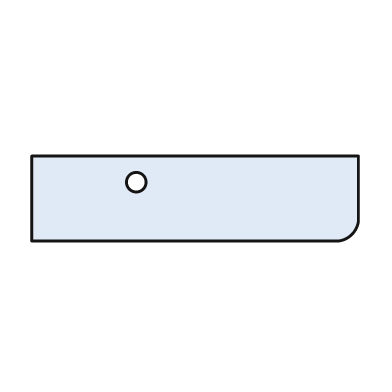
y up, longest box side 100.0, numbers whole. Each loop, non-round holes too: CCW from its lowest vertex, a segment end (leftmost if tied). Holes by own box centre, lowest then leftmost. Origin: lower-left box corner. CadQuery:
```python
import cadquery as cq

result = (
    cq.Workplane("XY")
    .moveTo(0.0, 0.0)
    .lineTo(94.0, 0.0)
    .threePointArc((98.0, 2.0), (100.0, 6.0))
    .lineTo(100.0, 26.0)
    .lineTo(0.0, 26.0)
    .close()
    .moveTo(32.0, 18.0)
    .circle(3.0)
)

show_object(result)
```